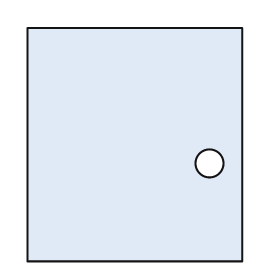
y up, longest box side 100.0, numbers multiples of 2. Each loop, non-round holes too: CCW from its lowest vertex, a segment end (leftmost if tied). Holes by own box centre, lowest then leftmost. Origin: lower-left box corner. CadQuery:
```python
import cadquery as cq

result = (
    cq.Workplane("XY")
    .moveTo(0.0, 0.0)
    .lineTo(92.0, 0.0)
    .lineTo(92.0, 100.0)
    .lineTo(0.0, 100.0)
    .close()
    .moveTo(78.0, 42.0)
    .circle(6.0)
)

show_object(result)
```